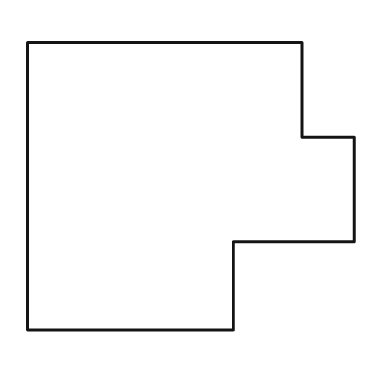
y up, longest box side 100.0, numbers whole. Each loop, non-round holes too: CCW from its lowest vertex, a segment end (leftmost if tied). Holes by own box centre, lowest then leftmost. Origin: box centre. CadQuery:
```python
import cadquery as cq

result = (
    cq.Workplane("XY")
    .moveTo(-50.0, -44.0)
    .lineTo(13.0, -44.0)
    .lineTo(13.0, -17.0)
    .lineTo(50.0, -17.0)
    .lineTo(50.0, 15.0)
    .lineTo(34.0, 15.0)
    .lineTo(34.0, 44.0)
    .lineTo(-50.0, 44.0)
    .close()
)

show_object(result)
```